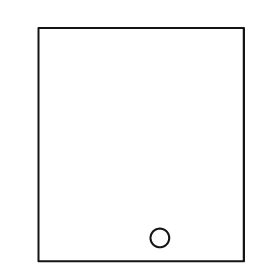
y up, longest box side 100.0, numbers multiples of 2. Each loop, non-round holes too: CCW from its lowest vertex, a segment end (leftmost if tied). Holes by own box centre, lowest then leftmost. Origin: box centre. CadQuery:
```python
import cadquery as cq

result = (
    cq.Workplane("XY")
    .moveTo(-44.0, -50.0)
    .lineTo(44.0, -50.0)
    .lineTo(44.0, 50.0)
    .lineTo(-44.0, 50.0)
    .close()
    .moveTo(8.0, -40.0)
    .circle(4.0)
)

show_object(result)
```